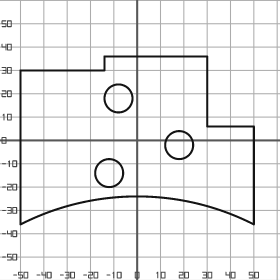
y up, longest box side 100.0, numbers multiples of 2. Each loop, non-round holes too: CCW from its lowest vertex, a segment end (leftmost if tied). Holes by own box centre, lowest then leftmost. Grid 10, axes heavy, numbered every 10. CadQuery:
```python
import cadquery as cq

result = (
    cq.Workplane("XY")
    .moveTo(-50.0, -36.0)
    .threePointArc((0.0, -24.0), (50.0, -36.0))
    .lineTo(50.0, 6.0)
    .lineTo(30.0, 6.0)
    .lineTo(30.0, 36.0)
    .lineTo(-14.0, 36.0)
    .lineTo(-14.0, 30.0)
    .lineTo(-50.0, 30.0)
    .close()
    .moveTo(-12.0, -14.0)
    .circle(6.0)
    .moveTo(18.0, -2.0)
    .circle(6.0)
    .moveTo(-8.0, 18.0)
    .circle(6.0)
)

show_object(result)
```